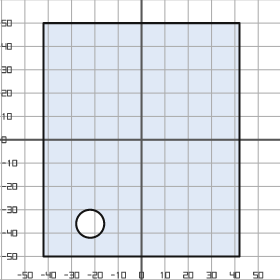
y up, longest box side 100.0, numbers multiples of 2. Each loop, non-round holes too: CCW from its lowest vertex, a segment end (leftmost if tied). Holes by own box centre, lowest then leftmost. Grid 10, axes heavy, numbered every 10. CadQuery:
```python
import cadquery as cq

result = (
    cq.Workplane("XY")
    .moveTo(-42.0, -50.0)
    .lineTo(42.0, -50.0)
    .lineTo(42.0, 50.0)
    .lineTo(-42.0, 50.0)
    .close()
    .moveTo(-22.0, -36.0)
    .circle(6.0)
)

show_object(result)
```